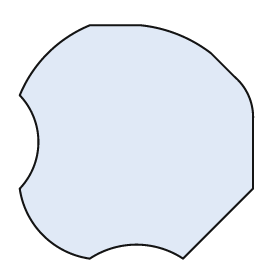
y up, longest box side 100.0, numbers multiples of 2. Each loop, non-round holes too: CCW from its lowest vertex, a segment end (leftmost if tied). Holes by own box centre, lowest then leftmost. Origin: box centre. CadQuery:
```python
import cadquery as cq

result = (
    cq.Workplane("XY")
    .moveTo(-20.0, -50.0)
    .threePointArc((0.0, -44.0), (20.0, -50.0))
    .lineTo(50.0, -20.0)
    .lineTo(50.0, 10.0)
    .threePointArc((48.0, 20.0), (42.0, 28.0))
    .lineTo(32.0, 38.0)
    .threePointArc((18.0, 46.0), (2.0, 50.0))
    .lineTo(-20.0, 50.0)
    .threePointArc((-38.0, 38.0), (-50.0, 20.0))
    .threePointArc((-42.0, 0.0), (-50.0, -20.0))
    .threePointArc((-40.0, -40.0), (-20.0, -50.0))
    .close()
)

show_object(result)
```